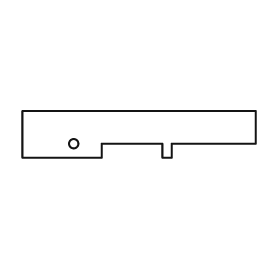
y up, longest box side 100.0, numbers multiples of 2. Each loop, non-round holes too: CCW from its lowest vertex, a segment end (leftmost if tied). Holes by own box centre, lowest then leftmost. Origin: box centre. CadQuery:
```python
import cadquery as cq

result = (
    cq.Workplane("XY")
    .moveTo(-50.0, -10.0)
    .lineTo(-16.0, -10.0)
    .lineTo(-16.0, -4.0)
    .lineTo(10.0, -4.0)
    .lineTo(10.0, -10.0)
    .lineTo(14.0, -10.0)
    .lineTo(14.0, -4.0)
    .lineTo(50.0, -4.0)
    .lineTo(50.0, 10.0)
    .lineTo(-50.0, 10.0)
    .close()
    .moveTo(-28.0, -4.0)
    .circle(2.0)
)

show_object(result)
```